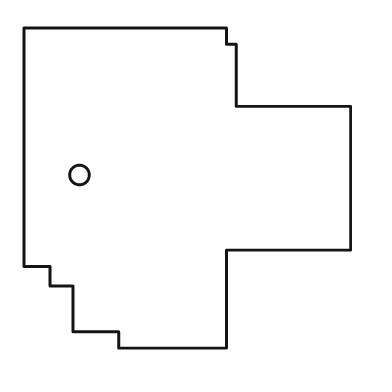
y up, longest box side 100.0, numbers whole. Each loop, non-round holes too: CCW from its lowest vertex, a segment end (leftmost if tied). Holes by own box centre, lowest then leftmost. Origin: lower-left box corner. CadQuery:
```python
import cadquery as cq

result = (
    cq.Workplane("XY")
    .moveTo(29.0, 0.0)
    .lineTo(62.0, 0.0)
    .lineTo(62.0, 30.0)
    .lineTo(100.0, 30.0)
    .lineTo(100.0, 74.0)
    .lineTo(65.0, 74.0)
    .lineTo(65.0, 93.0)
    .lineTo(62.0, 93.0)
    .lineTo(62.0, 98.0)
    .lineTo(0.0, 98.0)
    .lineTo(0.0, 25.0)
    .lineTo(8.0, 25.0)
    .lineTo(8.0, 19.0)
    .lineTo(15.0, 19.0)
    .lineTo(15.0, 5.0)
    .lineTo(29.0, 5.0)
    .close()
    .moveTo(17.0, 53.0)
    .circle(3.0)
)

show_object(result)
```